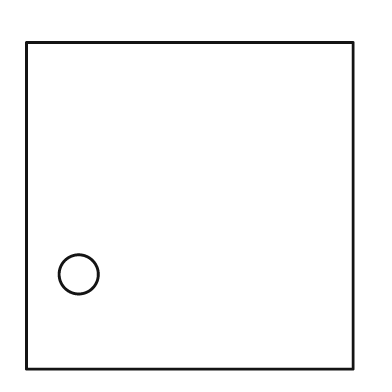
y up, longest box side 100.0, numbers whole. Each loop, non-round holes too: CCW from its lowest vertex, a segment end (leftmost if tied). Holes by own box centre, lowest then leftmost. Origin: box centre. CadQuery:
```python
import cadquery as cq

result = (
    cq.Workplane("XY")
    .moveTo(-50.0, -50.0)
    .lineTo(50.0, -50.0)
    .lineTo(50.0, 50.0)
    .lineTo(-50.0, 50.0)
    .close()
    .moveTo(-34.0, -21.0)
    .circle(6.0)
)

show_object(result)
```